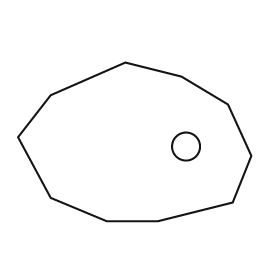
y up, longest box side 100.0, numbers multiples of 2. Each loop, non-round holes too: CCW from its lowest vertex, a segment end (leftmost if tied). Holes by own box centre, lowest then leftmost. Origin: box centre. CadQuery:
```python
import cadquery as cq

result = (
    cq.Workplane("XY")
    .moveTo(-12.0, -34.0)
    .lineTo(10.0, -34.0)
    .lineTo(42.0, -26.0)
    .lineTo(50.0, -6.0)
    .lineTo(40.0, 16.0)
    .lineTo(20.0, 28.0)
    .lineTo(-4.0, 34.0)
    .lineTo(-36.0, 20.0)
    .lineTo(-50.0, 2.0)
    .lineTo(-36.0, -24.0)
    .close()
    .moveTo(22.0, -2.0)
    .circle(6.0)
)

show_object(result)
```